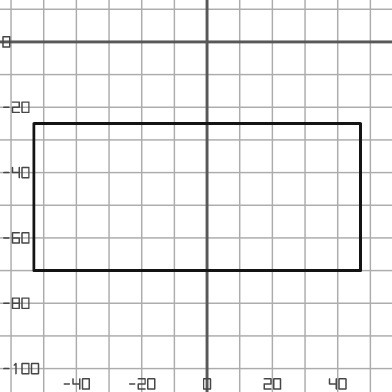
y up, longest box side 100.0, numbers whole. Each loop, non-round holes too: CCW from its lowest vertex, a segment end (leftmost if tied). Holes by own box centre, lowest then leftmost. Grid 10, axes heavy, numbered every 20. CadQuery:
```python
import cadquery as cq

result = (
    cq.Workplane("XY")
    .moveTo(-53.0, -70.0)
    .lineTo(47.0, -70.0)
    .lineTo(47.0, -25.0)
    .lineTo(-53.0, -25.0)
    .close()
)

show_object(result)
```